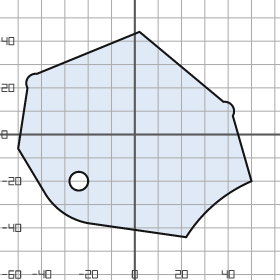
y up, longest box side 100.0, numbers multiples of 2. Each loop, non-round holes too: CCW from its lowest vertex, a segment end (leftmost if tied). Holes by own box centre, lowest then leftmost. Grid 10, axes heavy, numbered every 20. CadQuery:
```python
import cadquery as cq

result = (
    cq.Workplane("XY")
    .moveTo(22.0, -44.0)
    .threePointArc((34.0, -30.0), (50.0, -20.0))
    .lineTo(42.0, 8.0)
    .threePointArc((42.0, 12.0), (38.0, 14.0))
    .lineTo(2.0, 44.0)
    .lineTo(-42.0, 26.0)
    .threePointArc((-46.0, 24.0), (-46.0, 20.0))
    .lineTo(-50.0, -6.0)
    .lineTo(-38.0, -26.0)
    .threePointArc((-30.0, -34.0), (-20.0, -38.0))
    .close()
    .moveTo(-24.0, -20.0)
    .circle(4.0)
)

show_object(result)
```